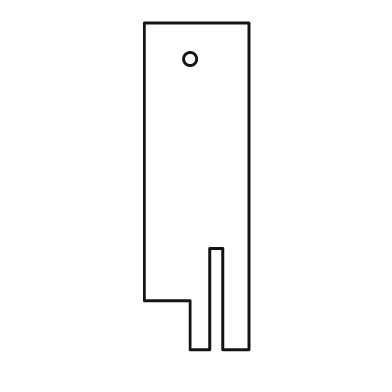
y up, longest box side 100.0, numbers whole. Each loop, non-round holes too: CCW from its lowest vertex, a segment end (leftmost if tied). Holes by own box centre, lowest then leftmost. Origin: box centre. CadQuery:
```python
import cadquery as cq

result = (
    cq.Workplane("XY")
    .moveTo(-2.0, -50.0)
    .lineTo(4.0, -50.0)
    .lineTo(4.0, -19.0)
    .lineTo(8.0, -19.0)
    .lineTo(8.0, -50.0)
    .lineTo(16.0, -50.0)
    .lineTo(16.0, 50.0)
    .lineTo(-16.0, 50.0)
    .lineTo(-16.0, -35.0)
    .lineTo(-2.0, -35.0)
    .close()
    .moveTo(-2.0, 39.0)
    .circle(2.0)
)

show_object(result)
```